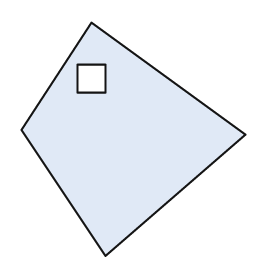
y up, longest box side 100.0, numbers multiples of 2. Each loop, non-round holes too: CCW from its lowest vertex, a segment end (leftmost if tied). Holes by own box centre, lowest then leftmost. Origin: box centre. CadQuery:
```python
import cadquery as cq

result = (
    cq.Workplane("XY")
    .moveTo(-12.0, -50.0)
    .lineTo(48.0, 2.0)
    .lineTo(-18.0, 50.0)
    .lineTo(-48.0, 4.0)
    .close()
    .moveTo(-24.0, 20.0)
    .lineTo(-12.0, 20.0)
    .lineTo(-12.0, 32.0)
    .lineTo(-24.0, 32.0)
    .close()
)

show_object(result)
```